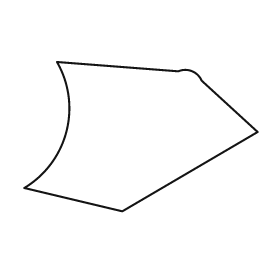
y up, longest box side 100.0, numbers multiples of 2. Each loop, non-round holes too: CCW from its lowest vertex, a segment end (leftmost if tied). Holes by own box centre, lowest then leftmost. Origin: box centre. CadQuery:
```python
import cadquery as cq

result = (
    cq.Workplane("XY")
    .moveTo(-8.0, -32.0)
    .lineTo(50.0, 2.0)
    .lineTo(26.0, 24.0)
    .threePointArc((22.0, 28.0), (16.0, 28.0))
    .lineTo(-36.0, 32.0)
    .threePointArc((-32.0, 2.0), (-50.0, -22.0))
    .close()
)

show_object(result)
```